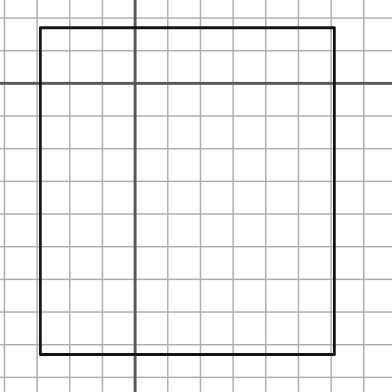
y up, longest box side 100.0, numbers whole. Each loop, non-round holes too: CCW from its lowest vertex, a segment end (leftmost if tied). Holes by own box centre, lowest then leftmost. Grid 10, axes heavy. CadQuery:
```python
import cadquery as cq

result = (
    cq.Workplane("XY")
    .moveTo(-29.0, -83.0)
    .lineTo(61.0, -83.0)
    .lineTo(61.0, 17.0)
    .lineTo(-29.0, 17.0)
    .close()
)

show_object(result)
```